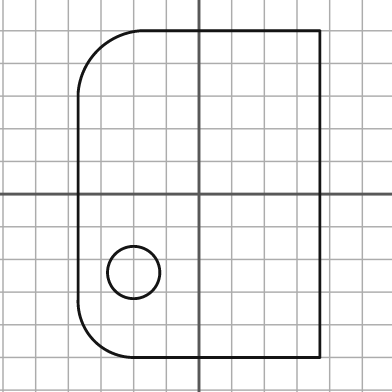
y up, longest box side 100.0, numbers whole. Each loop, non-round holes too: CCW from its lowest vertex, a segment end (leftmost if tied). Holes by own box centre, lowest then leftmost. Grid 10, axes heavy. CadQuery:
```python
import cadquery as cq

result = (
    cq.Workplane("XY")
    .moveTo(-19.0, -50.0)
    .lineTo(37.0, -50.0)
    .lineTo(37.0, 50.0)
    .lineTo(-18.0, 50.0)
    .threePointArc((-31.0, 44.0), (-37.0, 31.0))
    .lineTo(-37.0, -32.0)
    .threePointArc((-32.0, -45.0), (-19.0, -50.0))
    .close()
    .moveTo(-20.0, -24.0)
    .circle(8.0)
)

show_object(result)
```